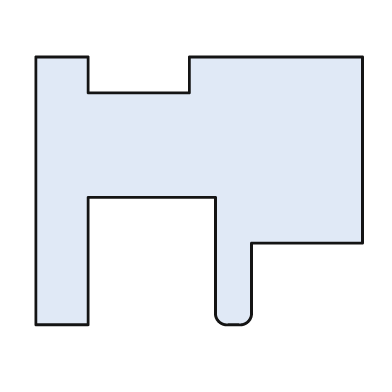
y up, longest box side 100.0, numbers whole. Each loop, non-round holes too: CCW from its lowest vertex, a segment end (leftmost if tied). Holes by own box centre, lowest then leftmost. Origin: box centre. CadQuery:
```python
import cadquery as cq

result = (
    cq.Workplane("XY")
    .moveTo(-50.0, -41.0)
    .lineTo(-34.0, -41.0)
    .lineTo(-34.0, -2.0)
    .lineTo(5.0, -2.0)
    .lineTo(5.0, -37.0)
    .threePointArc((6.0, -40.0), (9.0, -41.0))
    .lineTo(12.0, -41.0)
    .threePointArc((15.0, -40.0), (16.0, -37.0))
    .lineTo(16.0, -16.0)
    .lineTo(50.0, -16.0)
    .lineTo(50.0, 41.0)
    .lineTo(-3.0, 41.0)
    .lineTo(-3.0, 30.0)
    .lineTo(-34.0, 30.0)
    .lineTo(-34.0, 41.0)
    .lineTo(-50.0, 41.0)
    .close()
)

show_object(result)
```